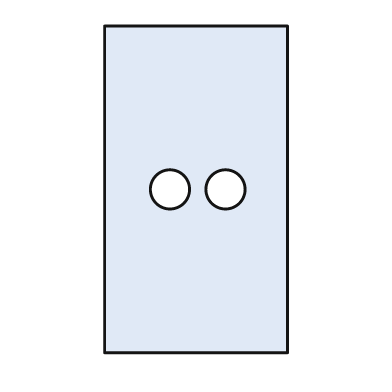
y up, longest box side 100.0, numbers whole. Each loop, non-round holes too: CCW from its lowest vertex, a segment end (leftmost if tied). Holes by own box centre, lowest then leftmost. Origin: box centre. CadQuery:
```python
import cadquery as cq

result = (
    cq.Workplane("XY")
    .moveTo(-28.0, -50.0)
    .lineTo(28.0, -50.0)
    .lineTo(28.0, 50.0)
    .lineTo(-28.0, 50.0)
    .close()
    .moveTo(-8.0, 0.0)
    .circle(6.0)
    .moveTo(9.0, 0.0)
    .circle(6.0)
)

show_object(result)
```